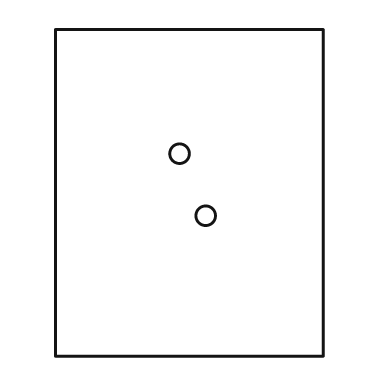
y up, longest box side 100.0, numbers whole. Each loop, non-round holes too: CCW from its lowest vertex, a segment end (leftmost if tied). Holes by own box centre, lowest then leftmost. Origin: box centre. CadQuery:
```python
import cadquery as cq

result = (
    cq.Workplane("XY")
    .moveTo(-41.0, -50.0)
    .lineTo(41.0, -50.0)
    .lineTo(41.0, 50.0)
    .lineTo(-41.0, 50.0)
    .close()
    .moveTo(5.0, -7.0)
    .circle(3.0)
    .moveTo(-3.0, 12.0)
    .circle(3.0)
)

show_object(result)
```